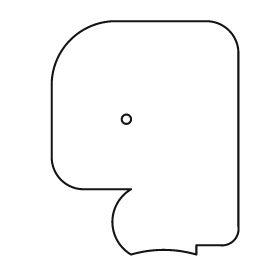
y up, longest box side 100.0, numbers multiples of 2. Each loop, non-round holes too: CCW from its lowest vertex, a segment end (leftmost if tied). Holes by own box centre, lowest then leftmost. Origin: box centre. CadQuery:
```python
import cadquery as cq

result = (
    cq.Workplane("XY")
    .moveTo(-6.0, -50.0)
    .threePointArc((8.0, -48.0), (22.0, -50.0))
    .lineTo(22.0, -46.0)
    .lineTo(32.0, -46.0)
    .threePointArc((38.0, -44.0), (40.0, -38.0))
    .lineTo(40.0, 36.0)
    .threePointArc((36.0, 46.0), (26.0, 50.0))
    .lineTo(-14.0, 50.0)
    .threePointArc((-32.0, 42.0), (-40.0, 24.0))
    .lineTo(-40.0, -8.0)
    .threePointArc((-36.0, -18.0), (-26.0, -22.0))
    .lineTo(-6.0, -22.0)
    .threePointArc((-14.0, -36.0), (-6.0, -50.0))
    .close()
    .moveTo(-8.0, 8.0)
    .circle(2.0)
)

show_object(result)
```